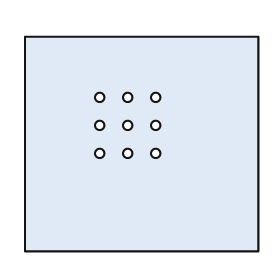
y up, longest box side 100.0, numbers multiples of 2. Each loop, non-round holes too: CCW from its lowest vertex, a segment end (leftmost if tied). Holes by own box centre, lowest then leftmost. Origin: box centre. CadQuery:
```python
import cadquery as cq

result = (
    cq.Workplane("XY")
    .moveTo(-50.0, -46.0)
    .lineTo(50.0, -46.0)
    .lineTo(50.0, 46.0)
    .lineTo(-50.0, 46.0)
    .close()
    .moveTo(-18.0, -4.0)
    .circle(2.0)
    .moveTo(-6.0, -4.0)
    .circle(2.0)
    .moveTo(6.0, -4.0)
    .circle(2.0)
    .moveTo(-18.0, 8.0)
    .circle(2.0)
    .moveTo(-6.0, 8.0)
    .circle(2.0)
    .moveTo(6.0, 8.0)
    .circle(2.0)
    .moveTo(-18.0, 20.0)
    .circle(2.0)
    .moveTo(-6.0, 20.0)
    .circle(2.0)
    .moveTo(6.0, 20.0)
    .circle(2.0)
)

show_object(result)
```